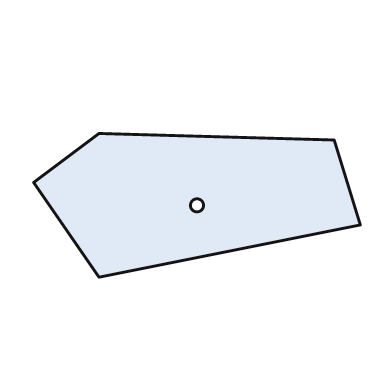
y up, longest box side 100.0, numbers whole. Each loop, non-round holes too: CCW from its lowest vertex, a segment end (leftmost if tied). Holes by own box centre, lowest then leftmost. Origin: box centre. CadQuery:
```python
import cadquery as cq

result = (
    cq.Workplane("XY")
    .moveTo(-30.0, -22.0)
    .lineTo(50.0, -6.0)
    .lineTo(42.0, 20.0)
    .lineTo(-30.0, 22.0)
    .lineTo(-50.0, 7.0)
    .close()
    .moveTo(0.0, 0.0)
    .circle(2.0)
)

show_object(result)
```